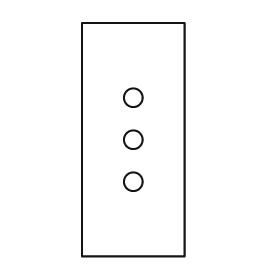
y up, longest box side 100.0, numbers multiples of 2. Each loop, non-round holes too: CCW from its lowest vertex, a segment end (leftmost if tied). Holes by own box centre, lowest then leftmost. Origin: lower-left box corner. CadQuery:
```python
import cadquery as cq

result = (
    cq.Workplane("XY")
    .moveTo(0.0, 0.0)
    .lineTo(44.0, 0.0)
    .lineTo(44.0, 100.0)
    .lineTo(0.0, 100.0)
    .close()
    .moveTo(22.0, 32.0)
    .circle(4.0)
    .moveTo(22.0, 50.0)
    .circle(4.0)
    .moveTo(22.0, 68.0)
    .circle(4.0)
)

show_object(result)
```